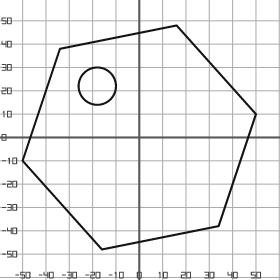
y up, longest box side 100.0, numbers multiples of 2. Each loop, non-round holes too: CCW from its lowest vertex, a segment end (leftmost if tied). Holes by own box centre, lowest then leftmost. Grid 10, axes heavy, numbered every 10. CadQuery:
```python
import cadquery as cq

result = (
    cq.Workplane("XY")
    .moveTo(-16.0, -48.0)
    .lineTo(34.0, -38.0)
    .lineTo(50.0, 10.0)
    .lineTo(16.0, 48.0)
    .lineTo(-34.0, 38.0)
    .lineTo(-50.0, -10.0)
    .close()
    .moveTo(-18.0, 22.0)
    .circle(8.0)
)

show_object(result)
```